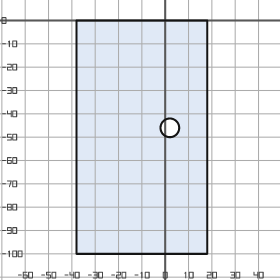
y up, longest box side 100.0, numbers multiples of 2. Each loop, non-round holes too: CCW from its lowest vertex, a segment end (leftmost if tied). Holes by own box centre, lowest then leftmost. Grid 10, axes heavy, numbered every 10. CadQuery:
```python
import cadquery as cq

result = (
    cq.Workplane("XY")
    .moveTo(-38.0, -100.0)
    .lineTo(18.0, -100.0)
    .lineTo(18.0, 0.0)
    .lineTo(-38.0, 0.0)
    .close()
    .moveTo(2.0, -46.0)
    .circle(4.0)
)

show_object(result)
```